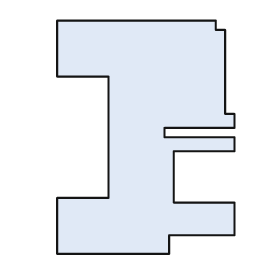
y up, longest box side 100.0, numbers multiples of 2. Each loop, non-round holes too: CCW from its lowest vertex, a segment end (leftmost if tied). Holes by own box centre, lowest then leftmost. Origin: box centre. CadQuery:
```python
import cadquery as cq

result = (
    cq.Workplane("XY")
    .moveTo(-38.0, -50.0)
    .lineTo(10.0, -50.0)
    .lineTo(10.0, -42.0)
    .lineTo(38.0, -42.0)
    .lineTo(38.0, -28.0)
    .lineTo(12.0, -28.0)
    .lineTo(12.0, -6.0)
    .lineTo(38.0, -6.0)
    .lineTo(38.0, 0.0)
    .lineTo(8.0, 0.0)
    .lineTo(8.0, 4.0)
    .lineTo(38.0, 4.0)
    .lineTo(38.0, 10.0)
    .lineTo(34.0, 10.0)
    .lineTo(34.0, 46.0)
    .lineTo(30.0, 46.0)
    .lineTo(30.0, 50.0)
    .lineTo(-38.0, 50.0)
    .lineTo(-38.0, 26.0)
    .lineTo(-16.0, 26.0)
    .lineTo(-16.0, -26.0)
    .lineTo(-38.0, -26.0)
    .close()
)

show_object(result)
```